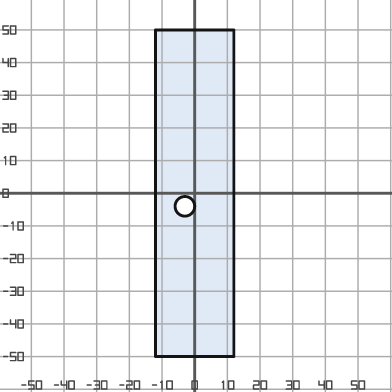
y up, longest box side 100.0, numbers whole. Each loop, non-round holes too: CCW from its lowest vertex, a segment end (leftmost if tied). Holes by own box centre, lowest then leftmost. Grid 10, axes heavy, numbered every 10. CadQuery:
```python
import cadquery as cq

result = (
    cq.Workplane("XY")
    .moveTo(-12.0, -50.0)
    .lineTo(12.0, -50.0)
    .lineTo(12.0, 50.0)
    .lineTo(-12.0, 50.0)
    .close()
    .moveTo(-3.0, -4.0)
    .circle(3.0)
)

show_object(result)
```